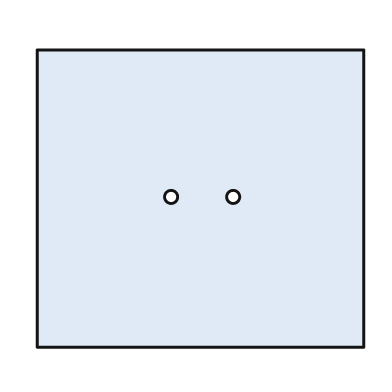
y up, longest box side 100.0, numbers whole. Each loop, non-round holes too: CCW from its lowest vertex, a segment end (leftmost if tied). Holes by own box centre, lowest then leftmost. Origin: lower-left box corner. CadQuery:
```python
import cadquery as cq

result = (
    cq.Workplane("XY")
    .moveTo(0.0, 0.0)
    .lineTo(100.0, 0.0)
    .lineTo(100.0, 91.0)
    .lineTo(0.0, 91.0)
    .close()
    .moveTo(41.0, 46.0)
    .circle(2.0)
    .moveTo(60.0, 46.0)
    .circle(2.0)
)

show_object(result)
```